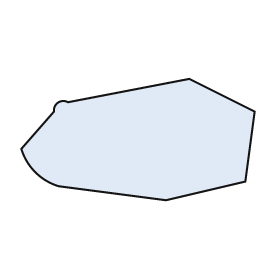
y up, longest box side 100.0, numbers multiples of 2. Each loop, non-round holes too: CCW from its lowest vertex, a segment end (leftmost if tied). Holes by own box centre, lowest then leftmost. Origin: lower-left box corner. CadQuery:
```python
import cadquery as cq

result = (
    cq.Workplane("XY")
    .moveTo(62.0, 0.0)
    .lineTo(96.0, 8.0)
    .lineTo(100.0, 38.0)
    .lineTo(72.0, 52.0)
    .lineTo(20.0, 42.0)
    .threePointArc((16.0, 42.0), (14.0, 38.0))
    .lineTo(0.0, 22.0)
    .threePointArc((6.0, 12.0), (16.0, 6.0))
    .close()
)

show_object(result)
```